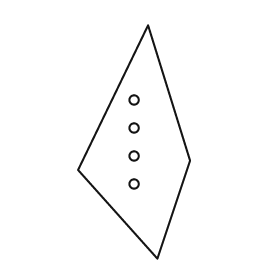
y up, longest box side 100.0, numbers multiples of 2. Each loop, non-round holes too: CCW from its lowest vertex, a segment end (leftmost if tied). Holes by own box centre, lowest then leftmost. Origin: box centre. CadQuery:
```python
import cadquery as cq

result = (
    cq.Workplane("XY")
    .moveTo(10.0, -50.0)
    .lineTo(24.0, -8.0)
    .lineTo(6.0, 50.0)
    .lineTo(-24.0, -12.0)
    .close()
    .moveTo(0.0, -18.0)
    .circle(2.0)
    .moveTo(0.0, -6.0)
    .circle(2.0)
    .moveTo(0.0, 6.0)
    .circle(2.0)
    .moveTo(0.0, 18.0)
    .circle(2.0)
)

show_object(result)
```